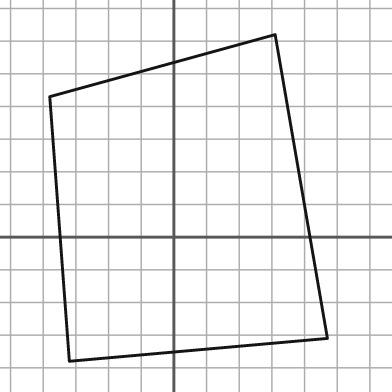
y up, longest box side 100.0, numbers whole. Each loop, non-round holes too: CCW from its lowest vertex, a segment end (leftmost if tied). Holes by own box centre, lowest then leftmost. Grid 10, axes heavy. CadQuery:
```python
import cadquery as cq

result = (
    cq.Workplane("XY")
    .moveTo(-32.0, -38.0)
    .lineTo(47.0, -31.0)
    .lineTo(31.0, 62.0)
    .lineTo(-38.0, 43.0)
    .close()
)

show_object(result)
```